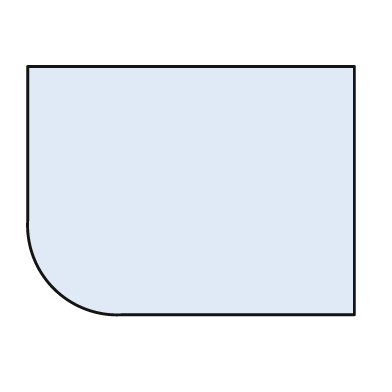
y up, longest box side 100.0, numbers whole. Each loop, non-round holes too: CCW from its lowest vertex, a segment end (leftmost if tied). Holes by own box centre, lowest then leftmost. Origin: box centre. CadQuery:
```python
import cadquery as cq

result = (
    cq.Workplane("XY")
    .moveTo(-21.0, -38.0)
    .lineTo(50.0, -38.0)
    .lineTo(50.0, 38.0)
    .lineTo(-50.0, 38.0)
    .lineTo(-50.0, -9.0)
    .threePointArc((-42.0, -30.0), (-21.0, -38.0))
    .close()
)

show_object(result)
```